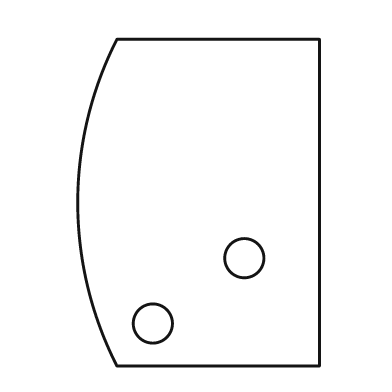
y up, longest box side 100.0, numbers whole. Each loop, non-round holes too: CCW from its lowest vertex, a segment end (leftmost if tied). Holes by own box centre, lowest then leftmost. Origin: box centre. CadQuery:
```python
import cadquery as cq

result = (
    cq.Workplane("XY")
    .moveTo(-25.0, -50.0)
    .lineTo(37.0, -50.0)
    .lineTo(37.0, 50.0)
    .lineTo(-25.0, 50.0)
    .threePointArc((-37.0, 0.0), (-25.0, -50.0))
    .close()
    .moveTo(-14.0, -37.0)
    .circle(6.0)
    .moveTo(14.0, -17.0)
    .circle(6.0)
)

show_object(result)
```